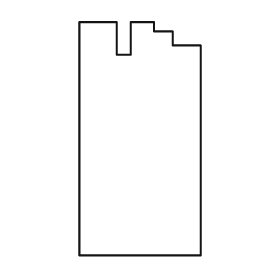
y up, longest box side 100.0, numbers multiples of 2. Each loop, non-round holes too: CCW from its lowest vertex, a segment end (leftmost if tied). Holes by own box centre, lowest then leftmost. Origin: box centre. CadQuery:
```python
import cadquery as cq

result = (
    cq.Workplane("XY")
    .moveTo(-26.0, -50.0)
    .lineTo(26.0, -50.0)
    .lineTo(26.0, 40.0)
    .lineTo(14.0, 40.0)
    .lineTo(14.0, 46.0)
    .lineTo(6.0, 46.0)
    .lineTo(6.0, 50.0)
    .lineTo(-4.0, 50.0)
    .lineTo(-4.0, 36.0)
    .lineTo(-10.0, 36.0)
    .lineTo(-10.0, 50.0)
    .lineTo(-26.0, 50.0)
    .close()
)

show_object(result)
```